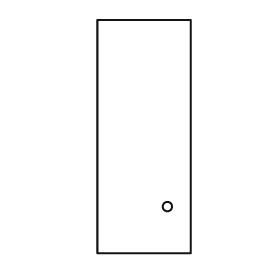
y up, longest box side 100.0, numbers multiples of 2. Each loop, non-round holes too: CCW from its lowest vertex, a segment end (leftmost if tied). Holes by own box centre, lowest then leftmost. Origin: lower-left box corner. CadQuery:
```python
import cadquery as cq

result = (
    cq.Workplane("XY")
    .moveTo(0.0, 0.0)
    .lineTo(40.0, 0.0)
    .lineTo(40.0, 100.0)
    .lineTo(0.0, 100.0)
    .close()
    .moveTo(30.0, 20.0)
    .circle(2.0)
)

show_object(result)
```